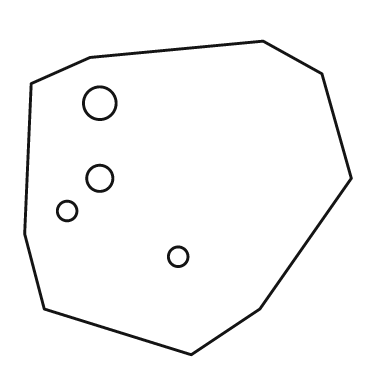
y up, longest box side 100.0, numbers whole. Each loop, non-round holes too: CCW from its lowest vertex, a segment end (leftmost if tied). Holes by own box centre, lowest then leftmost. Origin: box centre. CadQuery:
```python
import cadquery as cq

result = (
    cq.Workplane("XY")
    .moveTo(1.0, -48.0)
    .lineTo(22.0, -34.0)
    .lineTo(50.0, 6.0)
    .lineTo(41.0, 38.0)
    .lineTo(23.0, 48.0)
    .lineTo(-30.0, 43.0)
    .lineTo(-48.0, 35.0)
    .lineTo(-50.0, -11.0)
    .lineTo(-44.0, -34.0)
    .close()
    .moveTo(-3.0, -18.0)
    .circle(3.0)
    .moveTo(-37.0, -4.0)
    .circle(3.0)
    .moveTo(-27.0, 6.0)
    .circle(4.0)
    .moveTo(-27.0, 29.0)
    .circle(5.0)
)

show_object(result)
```